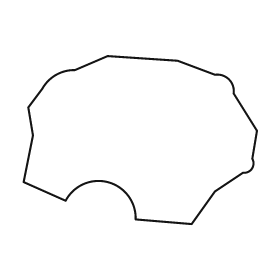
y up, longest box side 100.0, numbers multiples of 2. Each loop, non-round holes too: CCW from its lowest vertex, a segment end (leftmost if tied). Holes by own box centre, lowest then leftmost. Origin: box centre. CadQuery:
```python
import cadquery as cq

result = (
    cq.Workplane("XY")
    .moveTo(22.0, -36.0)
    .lineTo(32.0, -22.0)
    .lineTo(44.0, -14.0)
    .threePointArc((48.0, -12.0), (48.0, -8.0))
    .lineTo(50.0, 4.0)
    .lineTo(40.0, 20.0)
    .threePointArc((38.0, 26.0), (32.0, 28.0))
    .lineTo(16.0, 34.0)
    .lineTo(-14.0, 36.0)
    .lineTo(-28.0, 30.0)
    .threePointArc((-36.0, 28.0), (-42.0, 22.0))
    .lineTo(-48.0, 14.0)
    .lineTo(-46.0, 2.0)
    .lineTo(-50.0, -18.0)
    .lineTo(-32.0, -26.0)
    .threePointArc((-14.0, -18.0), (-2.0, -34.0))
    .close()
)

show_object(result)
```